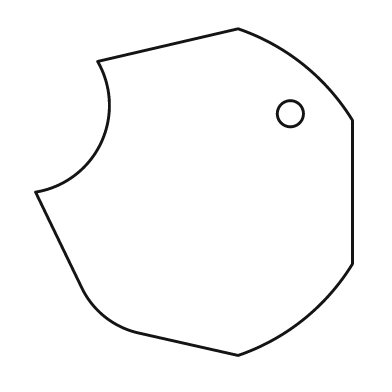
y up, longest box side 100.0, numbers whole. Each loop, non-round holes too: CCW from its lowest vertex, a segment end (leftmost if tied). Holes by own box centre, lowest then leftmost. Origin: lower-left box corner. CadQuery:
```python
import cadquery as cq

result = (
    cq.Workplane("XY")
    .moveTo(62.0, 0.0)
    .threePointArc((82.0, 11.0), (97.0, 28.0))
    .lineTo(97.0, 72.0)
    .threePointArc((82.0, 89.0), (62.0, 100.0))
    .lineTo(19.0, 90.0)
    .threePointArc((20.0, 65.0), (0.0, 50.0))
    .lineTo(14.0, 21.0)
    .threePointArc((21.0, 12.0), (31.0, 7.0))
    .close()
    .moveTo(78.0, 74.0)
    .circle(4.0)
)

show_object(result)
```